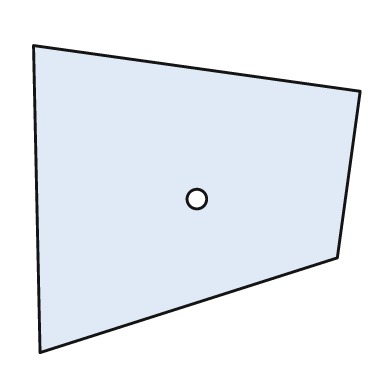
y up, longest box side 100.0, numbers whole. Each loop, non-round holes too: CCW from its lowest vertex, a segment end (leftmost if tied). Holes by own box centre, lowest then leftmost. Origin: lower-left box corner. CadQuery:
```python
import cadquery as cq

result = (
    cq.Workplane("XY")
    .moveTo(2.0, 0.0)
    .lineTo(93.0, 29.0)
    .lineTo(100.0, 80.0)
    .lineTo(0.0, 94.0)
    .close()
    .moveTo(50.0, 47.0)
    .circle(3.0)
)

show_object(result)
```